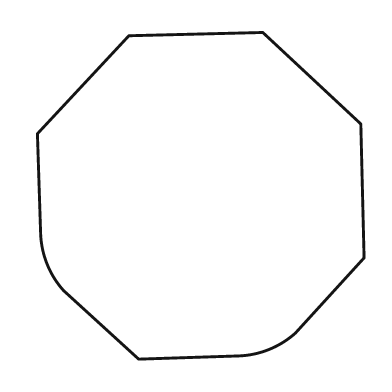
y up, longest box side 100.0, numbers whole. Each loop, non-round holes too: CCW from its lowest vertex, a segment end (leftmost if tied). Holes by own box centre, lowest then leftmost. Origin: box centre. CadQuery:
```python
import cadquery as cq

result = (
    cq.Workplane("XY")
    .moveTo(-19.0, -50.0)
    .lineTo(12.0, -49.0)
    .threePointArc((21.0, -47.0), (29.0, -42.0))
    .lineTo(50.0, -19.0)
    .lineTo(49.0, 22.0)
    .lineTo(19.0, 50.0)
    .lineTo(-22.0, 49.0)
    .lineTo(-50.0, 19.0)
    .lineTo(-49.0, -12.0)
    .threePointArc((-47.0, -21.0), (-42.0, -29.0))
    .close()
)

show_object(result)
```